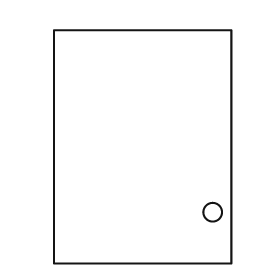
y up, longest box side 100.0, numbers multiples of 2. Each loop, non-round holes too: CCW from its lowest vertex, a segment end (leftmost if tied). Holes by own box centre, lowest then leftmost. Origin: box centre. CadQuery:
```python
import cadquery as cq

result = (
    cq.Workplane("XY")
    .moveTo(-38.0, -50.0)
    .lineTo(38.0, -50.0)
    .lineTo(38.0, 50.0)
    .lineTo(-38.0, 50.0)
    .close()
    .moveTo(30.0, -28.0)
    .circle(4.0)
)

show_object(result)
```